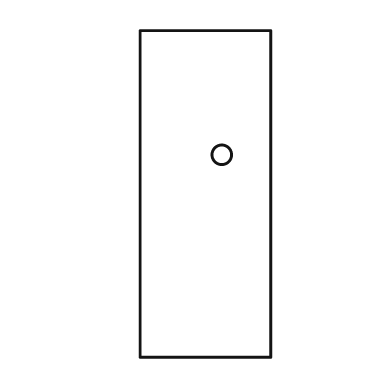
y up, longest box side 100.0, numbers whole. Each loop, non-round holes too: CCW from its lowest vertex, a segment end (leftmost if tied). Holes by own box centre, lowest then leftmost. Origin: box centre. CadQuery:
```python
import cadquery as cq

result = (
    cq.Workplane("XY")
    .moveTo(-20.0, -50.0)
    .lineTo(20.0, -50.0)
    .lineTo(20.0, 50.0)
    .lineTo(-20.0, 50.0)
    .close()
    .moveTo(5.0, 12.0)
    .circle(3.0)
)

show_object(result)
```